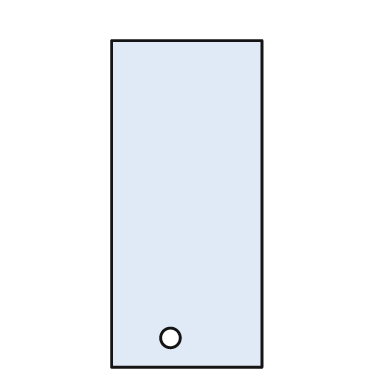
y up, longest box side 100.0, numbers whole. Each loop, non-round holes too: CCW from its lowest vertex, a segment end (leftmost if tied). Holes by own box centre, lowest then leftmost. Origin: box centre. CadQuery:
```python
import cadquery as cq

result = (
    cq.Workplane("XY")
    .moveTo(-23.0, -50.0)
    .lineTo(23.0, -50.0)
    .lineTo(23.0, 50.0)
    .lineTo(-23.0, 50.0)
    .close()
    .moveTo(-5.0, -41.0)
    .circle(3.0)
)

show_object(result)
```